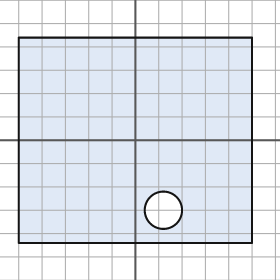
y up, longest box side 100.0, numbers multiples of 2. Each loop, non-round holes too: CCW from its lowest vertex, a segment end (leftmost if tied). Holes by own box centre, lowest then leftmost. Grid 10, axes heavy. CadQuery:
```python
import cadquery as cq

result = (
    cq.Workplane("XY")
    .moveTo(-50.0, -44.0)
    .lineTo(50.0, -44.0)
    .lineTo(50.0, 44.0)
    .lineTo(-50.0, 44.0)
    .close()
    .moveTo(12.0, -30.0)
    .circle(8.0)
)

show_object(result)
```